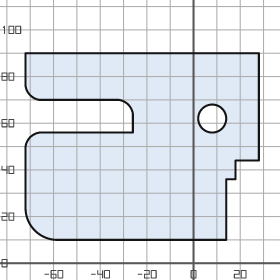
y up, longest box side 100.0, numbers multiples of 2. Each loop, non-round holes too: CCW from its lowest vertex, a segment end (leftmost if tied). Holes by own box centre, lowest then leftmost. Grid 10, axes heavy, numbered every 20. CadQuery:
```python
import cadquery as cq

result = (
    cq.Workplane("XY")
    .moveTo(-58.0, 10.0)
    .lineTo(14.0, 10.0)
    .lineTo(14.0, 36.0)
    .lineTo(18.0, 36.0)
    .lineTo(18.0, 44.0)
    .lineTo(28.0, 44.0)
    .lineTo(28.0, 90.0)
    .lineTo(-72.0, 90.0)
    .lineTo(-72.0, 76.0)
    .threePointArc((-70.0, 72.0), (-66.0, 70.0))
    .lineTo(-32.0, 70.0)
    .threePointArc((-28.0, 68.0), (-26.0, 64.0))
    .lineTo(-26.0, 56.0)
    .lineTo(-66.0, 56.0)
    .threePointArc((-70.0, 54.0), (-72.0, 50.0))
    .lineTo(-72.0, 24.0)
    .threePointArc((-68.0, 14.0), (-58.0, 10.0))
    .close()
    .moveTo(8.0, 62.0)
    .circle(6.0)
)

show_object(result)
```